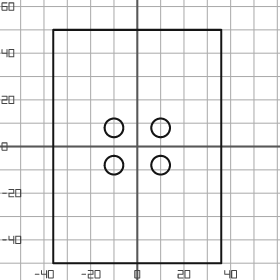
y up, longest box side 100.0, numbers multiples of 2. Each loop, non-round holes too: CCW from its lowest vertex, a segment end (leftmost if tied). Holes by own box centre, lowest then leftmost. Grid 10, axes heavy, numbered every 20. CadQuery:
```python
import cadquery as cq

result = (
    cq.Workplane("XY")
    .moveTo(-36.0, -50.0)
    .lineTo(36.0, -50.0)
    .lineTo(36.0, 50.0)
    .lineTo(-36.0, 50.0)
    .close()
    .moveTo(-10.0, -8.0)
    .circle(4.0)
    .moveTo(10.0, -8.0)
    .circle(4.0)
    .moveTo(-10.0, 8.0)
    .circle(4.0)
    .moveTo(10.0, 8.0)
    .circle(4.0)
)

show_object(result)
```